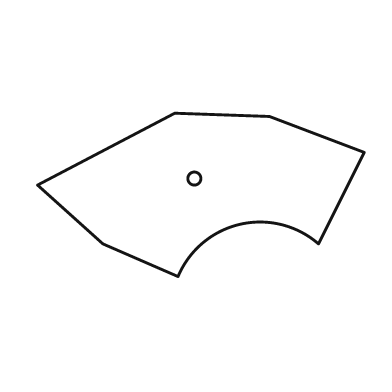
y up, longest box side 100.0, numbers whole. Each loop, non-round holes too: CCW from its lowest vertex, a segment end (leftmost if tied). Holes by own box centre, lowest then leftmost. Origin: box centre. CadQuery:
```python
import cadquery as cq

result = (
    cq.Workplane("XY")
    .moveTo(-7.0, -25.0)
    .threePointArc((12.0, -9.0), (36.0, -15.0))
    .lineTo(50.0, 13.0)
    .lineTo(21.0, 24.0)
    .lineTo(-8.0, 25.0)
    .lineTo(-50.0, 3.0)
    .lineTo(-30.0, -15.0)
    .close()
    .moveTo(-2.0, 5.0)
    .circle(2.0)
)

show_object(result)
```